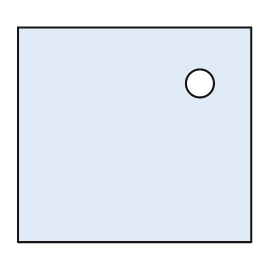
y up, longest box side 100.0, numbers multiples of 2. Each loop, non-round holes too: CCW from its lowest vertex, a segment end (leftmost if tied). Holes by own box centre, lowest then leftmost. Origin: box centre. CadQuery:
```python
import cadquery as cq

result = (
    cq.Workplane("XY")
    .moveTo(-50.0, -46.0)
    .lineTo(50.0, -46.0)
    .lineTo(50.0, 46.0)
    .lineTo(-50.0, 46.0)
    .close()
    .moveTo(28.0, 22.0)
    .circle(6.0)
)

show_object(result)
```